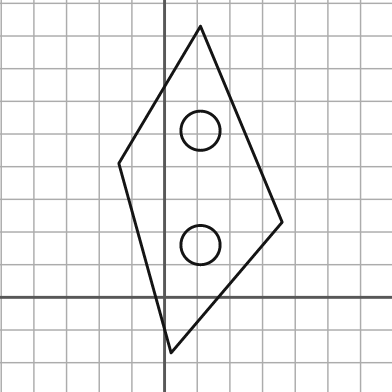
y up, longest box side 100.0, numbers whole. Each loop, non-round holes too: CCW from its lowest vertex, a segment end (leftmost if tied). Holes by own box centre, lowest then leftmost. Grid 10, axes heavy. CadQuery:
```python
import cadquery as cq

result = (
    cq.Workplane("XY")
    .moveTo(2.0, -17.0)
    .lineTo(36.0, 23.0)
    .lineTo(11.0, 83.0)
    .lineTo(-14.0, 41.0)
    .close()
    .moveTo(11.0, 16.0)
    .circle(6.0)
    .moveTo(11.0, 51.0)
    .circle(6.0)
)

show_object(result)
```